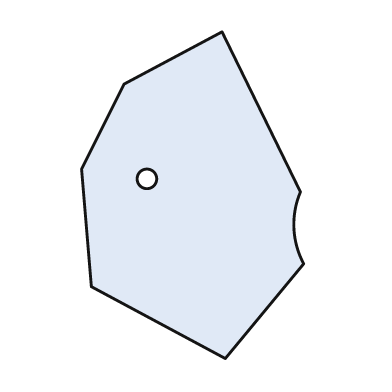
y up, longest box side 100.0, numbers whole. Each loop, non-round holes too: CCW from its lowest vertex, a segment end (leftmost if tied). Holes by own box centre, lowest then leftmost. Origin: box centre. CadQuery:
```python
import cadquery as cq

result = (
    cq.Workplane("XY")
    .moveTo(10.0, -50.0)
    .lineTo(34.0, -21.0)
    .threePointArc((31.0, -10.0), (33.0, 1.0))
    .lineTo(9.0, 50.0)
    .lineTo(-21.0, 34.0)
    .lineTo(-34.0, 8.0)
    .lineTo(-31.0, -28.0)
    .close()
    .moveTo(-14.0, 5.0)
    .circle(3.0)
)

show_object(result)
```